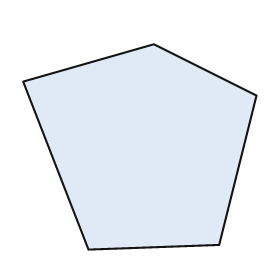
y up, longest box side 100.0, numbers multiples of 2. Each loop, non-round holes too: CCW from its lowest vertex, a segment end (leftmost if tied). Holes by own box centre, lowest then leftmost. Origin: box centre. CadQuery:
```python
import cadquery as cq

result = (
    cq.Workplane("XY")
    .moveTo(-22.0, -44.0)
    .lineTo(34.0, -42.0)
    .lineTo(50.0, 22.0)
    .lineTo(6.0, 44.0)
    .lineTo(-50.0, 28.0)
    .close()
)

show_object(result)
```